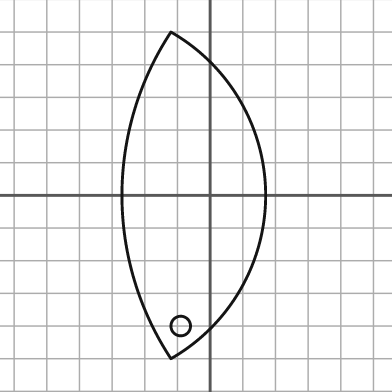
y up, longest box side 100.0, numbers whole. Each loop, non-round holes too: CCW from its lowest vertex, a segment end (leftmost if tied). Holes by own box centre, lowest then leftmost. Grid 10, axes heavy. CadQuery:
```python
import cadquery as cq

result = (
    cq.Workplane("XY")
    .moveTo(-12.0, -50.0)
    .threePointArc((17.0, 0.0), (-12.0, 50.0))
    .threePointArc((-27.0, 0.0), (-12.0, -50.0))
    .close()
    .moveTo(-9.0, -40.0)
    .circle(3.0)
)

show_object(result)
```